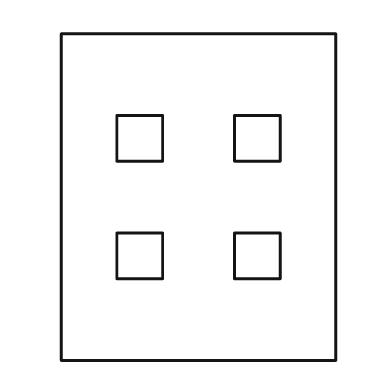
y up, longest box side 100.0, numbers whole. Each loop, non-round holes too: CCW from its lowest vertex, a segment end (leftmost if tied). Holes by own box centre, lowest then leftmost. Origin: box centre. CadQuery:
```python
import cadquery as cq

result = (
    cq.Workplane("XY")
    .moveTo(-42.0, -50.0)
    .lineTo(42.0, -50.0)
    .lineTo(42.0, 50.0)
    .lineTo(-42.0, 50.0)
    .close()
    .moveTo(-25.0, -25.0)
    .lineTo(-11.0, -25.0)
    .lineTo(-11.0, -11.0)
    .lineTo(-25.0, -11.0)
    .close()
    .moveTo(11.0, -25.0)
    .lineTo(25.0, -25.0)
    .lineTo(25.0, -11.0)
    .lineTo(11.0, -11.0)
    .close()
    .moveTo(-25.0, 11.0)
    .lineTo(-11.0, 11.0)
    .lineTo(-11.0, 25.0)
    .lineTo(-25.0, 25.0)
    .close()
    .moveTo(11.0, 11.0)
    .lineTo(25.0, 11.0)
    .lineTo(25.0, 25.0)
    .lineTo(11.0, 25.0)
    .close()
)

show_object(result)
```